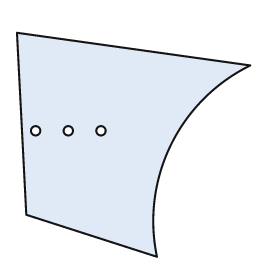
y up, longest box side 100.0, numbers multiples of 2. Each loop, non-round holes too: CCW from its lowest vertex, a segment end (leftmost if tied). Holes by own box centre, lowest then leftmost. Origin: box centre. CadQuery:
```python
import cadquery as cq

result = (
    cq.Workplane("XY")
    .moveTo(10.0, -48.0)
    .threePointArc((16.0, 0.0), (50.0, 34.0))
    .lineTo(-50.0, 48.0)
    .lineTo(-46.0, -30.0)
    .close()
    .moveTo(-42.0, 6.0)
    .circle(2.0)
    .moveTo(-28.0, 6.0)
    .circle(2.0)
    .moveTo(-14.0, 6.0)
    .circle(2.0)
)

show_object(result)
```